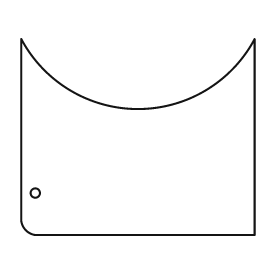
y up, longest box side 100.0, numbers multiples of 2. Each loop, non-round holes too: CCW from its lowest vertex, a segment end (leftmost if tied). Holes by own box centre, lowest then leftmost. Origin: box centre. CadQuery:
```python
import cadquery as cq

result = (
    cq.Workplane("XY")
    .moveTo(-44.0, -42.0)
    .lineTo(50.0, -42.0)
    .lineTo(50.0, 42.0)
    .threePointArc((0.0, 12.0), (-50.0, 42.0))
    .lineTo(-50.0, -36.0)
    .threePointArc((-48.0, -40.0), (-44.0, -42.0))
    .close()
    .moveTo(-44.0, -24.0)
    .circle(2.0)
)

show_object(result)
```